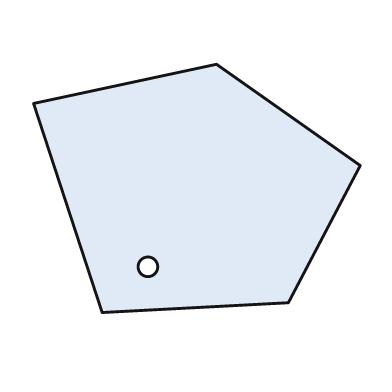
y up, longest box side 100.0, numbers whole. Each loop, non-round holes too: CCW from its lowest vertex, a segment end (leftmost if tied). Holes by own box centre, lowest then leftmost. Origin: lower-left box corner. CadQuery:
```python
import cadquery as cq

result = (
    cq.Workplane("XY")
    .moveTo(21.0, 0.0)
    .lineTo(78.0, 3.0)
    .lineTo(100.0, 45.0)
    .lineTo(56.0, 76.0)
    .lineTo(0.0, 64.0)
    .close()
    .moveTo(35.0, 14.0)
    .circle(3.0)
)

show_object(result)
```